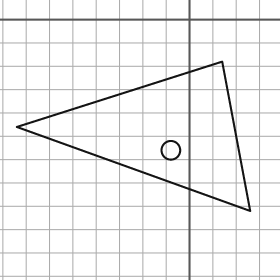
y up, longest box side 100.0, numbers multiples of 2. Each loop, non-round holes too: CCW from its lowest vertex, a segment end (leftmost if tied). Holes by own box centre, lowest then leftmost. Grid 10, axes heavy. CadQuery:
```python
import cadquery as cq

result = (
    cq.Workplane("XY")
    .moveTo(26.0, -82.0)
    .lineTo(14.0, -18.0)
    .lineTo(-74.0, -46.0)
    .close()
    .moveTo(-8.0, -56.0)
    .circle(4.0)
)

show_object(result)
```